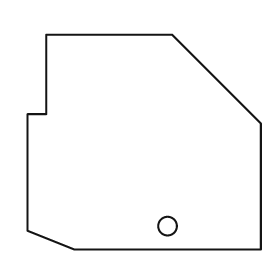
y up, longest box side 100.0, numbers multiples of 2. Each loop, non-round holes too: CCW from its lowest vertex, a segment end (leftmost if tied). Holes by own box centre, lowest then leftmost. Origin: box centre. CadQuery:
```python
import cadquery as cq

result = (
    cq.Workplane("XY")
    .moveTo(-30.0, -46.0)
    .lineTo(50.0, -46.0)
    .lineTo(50.0, 8.0)
    .lineTo(12.0, 46.0)
    .lineTo(-42.0, 46.0)
    .lineTo(-42.0, 12.0)
    .lineTo(-50.0, 12.0)
    .lineTo(-50.0, -38.0)
    .close()
    .moveTo(10.0, -36.0)
    .circle(4.0)
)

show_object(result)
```